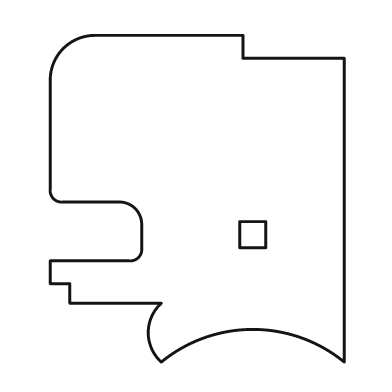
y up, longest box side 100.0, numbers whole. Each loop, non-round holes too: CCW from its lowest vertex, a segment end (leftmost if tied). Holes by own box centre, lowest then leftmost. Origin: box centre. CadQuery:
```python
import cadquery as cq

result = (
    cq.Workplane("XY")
    .moveTo(-11.0, -50.0)
    .threePointArc((17.0, -40.0), (45.0, -50.0))
    .lineTo(45.0, 43.0)
    .lineTo(14.0, 43.0)
    .lineTo(14.0, 50.0)
    .lineTo(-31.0, 50.0)
    .threePointArc((-41.0, 46.0), (-45.0, 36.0))
    .lineTo(-45.0, 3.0)
    .threePointArc((-44.0, 0.0), (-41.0, -1.0))
    .lineTo(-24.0, -1.0)
    .threePointArc((-19.0, -3.0), (-17.0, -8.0))
    .lineTo(-17.0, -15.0)
    .threePointArc((-18.0, -18.0), (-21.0, -19.0))
    .lineTo(-45.0, -19.0)
    .lineTo(-45.0, -26.0)
    .lineTo(-39.0, -26.0)
    .lineTo(-39.0, -32.0)
    .lineTo(-11.0, -32.0)
    .threePointArc((-15.0, -41.0), (-11.0, -50.0))
    .close()
    .moveTo(13.0, -15.0)
    .lineTo(21.0, -15.0)
    .lineTo(21.0, -7.0)
    .lineTo(13.0, -7.0)
    .close()
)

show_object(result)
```